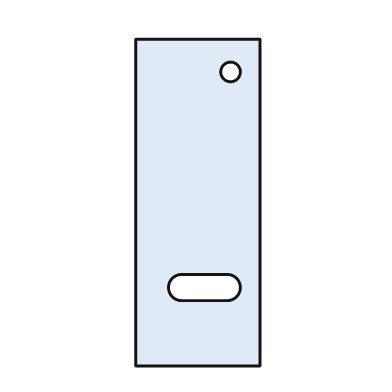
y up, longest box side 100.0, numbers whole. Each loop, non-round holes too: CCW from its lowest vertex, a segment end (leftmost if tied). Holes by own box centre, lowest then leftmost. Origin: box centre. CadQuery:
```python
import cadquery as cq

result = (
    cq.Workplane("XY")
    .moveTo(-19.0, -50.0)
    .lineTo(19.0, -50.0)
    .lineTo(19.0, 50.0)
    .lineTo(-19.0, 50.0)
    .close()
    .moveTo(-5.0, -30.0)
    .lineTo(9.0, -30.0)
    .threePointArc((13.0, -26.0), (9.0, -22.0))
    .lineTo(-5.0, -22.0)
    .threePointArc((-9.0, -26.0), (-5.0, -30.0))
    .close()
    .moveTo(10.0, 40.0)
    .circle(3.0)
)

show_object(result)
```